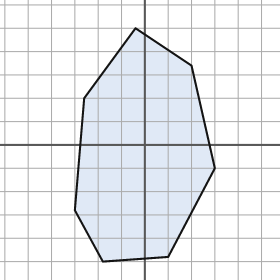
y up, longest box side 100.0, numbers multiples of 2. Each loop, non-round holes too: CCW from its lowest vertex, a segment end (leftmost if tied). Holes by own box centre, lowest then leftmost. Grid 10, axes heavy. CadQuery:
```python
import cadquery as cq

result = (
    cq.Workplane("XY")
    .moveTo(-18.0, -50.0)
    .lineTo(10.0, -48.0)
    .lineTo(30.0, -10.0)
    .lineTo(20.0, 34.0)
    .lineTo(-4.0, 50.0)
    .lineTo(-26.0, 20.0)
    .lineTo(-30.0, -28.0)
    .close()
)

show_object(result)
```